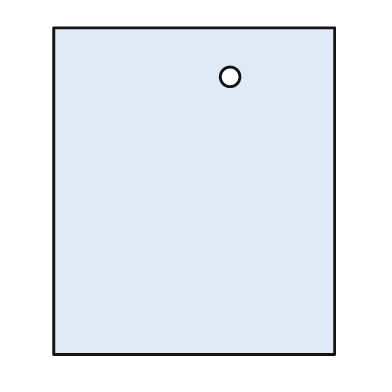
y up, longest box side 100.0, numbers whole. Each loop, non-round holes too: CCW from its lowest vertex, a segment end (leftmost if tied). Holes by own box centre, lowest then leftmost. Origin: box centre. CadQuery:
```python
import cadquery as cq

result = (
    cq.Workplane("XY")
    .moveTo(-43.0, -50.0)
    .lineTo(43.0, -50.0)
    .lineTo(43.0, 50.0)
    .lineTo(-43.0, 50.0)
    .close()
    .moveTo(11.0, 35.0)
    .circle(3.0)
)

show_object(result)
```